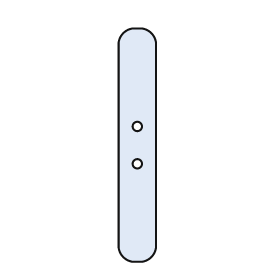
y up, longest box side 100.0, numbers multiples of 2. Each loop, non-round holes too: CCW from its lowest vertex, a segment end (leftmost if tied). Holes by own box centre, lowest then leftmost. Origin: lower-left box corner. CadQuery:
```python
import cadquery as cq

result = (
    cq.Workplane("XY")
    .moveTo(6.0, 0.0)
    .lineTo(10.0, 0.0)
    .threePointArc((14.0, 2.0), (16.0, 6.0))
    .lineTo(16.0, 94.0)
    .threePointArc((14.0, 98.0), (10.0, 100.0))
    .lineTo(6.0, 100.0)
    .threePointArc((2.0, 98.0), (0.0, 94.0))
    .lineTo(0.0, 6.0)
    .threePointArc((2.0, 2.0), (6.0, 0.0))
    .close()
    .moveTo(8.0, 42.0)
    .circle(2.0)
    .moveTo(8.0, 58.0)
    .circle(2.0)
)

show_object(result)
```